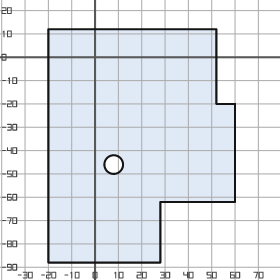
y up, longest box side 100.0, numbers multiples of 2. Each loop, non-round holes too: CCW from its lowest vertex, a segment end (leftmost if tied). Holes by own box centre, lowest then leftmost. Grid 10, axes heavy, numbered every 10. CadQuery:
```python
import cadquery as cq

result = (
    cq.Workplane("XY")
    .moveTo(-20.0, -88.0)
    .lineTo(28.0, -88.0)
    .lineTo(28.0, -62.0)
    .lineTo(60.0, -62.0)
    .lineTo(60.0, -20.0)
    .lineTo(52.0, -20.0)
    .lineTo(52.0, 12.0)
    .lineTo(-20.0, 12.0)
    .close()
    .moveTo(8.0, -46.0)
    .circle(4.0)
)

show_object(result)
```